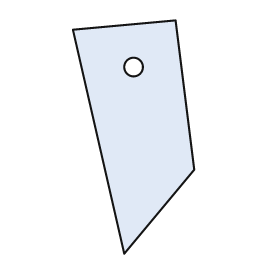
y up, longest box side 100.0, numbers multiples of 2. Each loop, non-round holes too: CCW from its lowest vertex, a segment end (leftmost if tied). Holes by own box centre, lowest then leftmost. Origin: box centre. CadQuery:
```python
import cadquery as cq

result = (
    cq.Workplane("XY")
    .moveTo(-4.0, -50.0)
    .lineTo(26.0, -14.0)
    .lineTo(18.0, 50.0)
    .lineTo(-26.0, 46.0)
    .close()
    .moveTo(0.0, 30.0)
    .circle(4.0)
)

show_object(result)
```